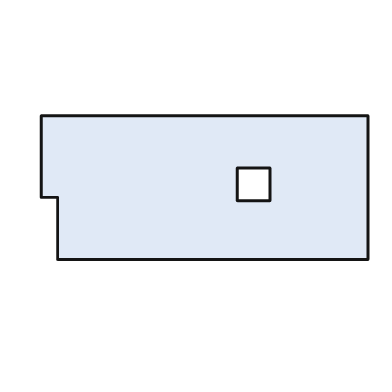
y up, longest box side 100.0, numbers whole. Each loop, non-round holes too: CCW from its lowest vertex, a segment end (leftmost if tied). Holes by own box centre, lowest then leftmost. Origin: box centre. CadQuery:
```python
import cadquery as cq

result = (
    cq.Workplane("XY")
    .moveTo(-45.0, -22.0)
    .lineTo(50.0, -22.0)
    .lineTo(50.0, 22.0)
    .lineTo(-50.0, 22.0)
    .lineTo(-50.0, -3.0)
    .lineTo(-45.0, -3.0)
    .close()
    .moveTo(10.0, -4.0)
    .lineTo(20.0, -4.0)
    .lineTo(20.0, 6.0)
    .lineTo(10.0, 6.0)
    .close()
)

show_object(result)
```